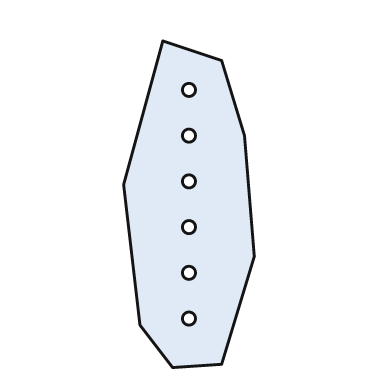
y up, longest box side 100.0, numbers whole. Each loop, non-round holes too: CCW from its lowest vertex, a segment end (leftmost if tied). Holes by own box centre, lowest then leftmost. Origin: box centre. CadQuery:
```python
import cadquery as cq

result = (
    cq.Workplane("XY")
    .moveTo(-5.0, -50.0)
    .lineTo(10.0, -49.0)
    .lineTo(20.0, -16.0)
    .lineTo(17.0, 21.0)
    .lineTo(10.0, 44.0)
    .lineTo(-8.0, 50.0)
    .lineTo(-20.0, 6.0)
    .lineTo(-15.0, -37.0)
    .close()
    .moveTo(0.0, -35.0)
    .circle(2.0)
    .moveTo(0.0, -21.0)
    .circle(2.0)
    .moveTo(0.0, -7.0)
    .circle(2.0)
    .moveTo(0.0, 7.0)
    .circle(2.0)
    .moveTo(0.0, 21.0)
    .circle(2.0)
    .moveTo(0.0, 35.0)
    .circle(2.0)
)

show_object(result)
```